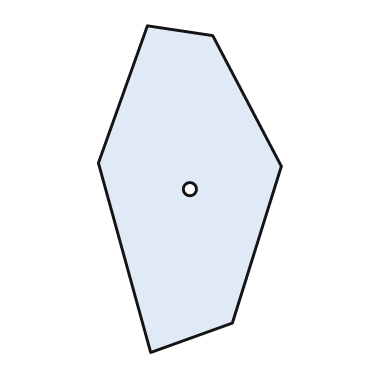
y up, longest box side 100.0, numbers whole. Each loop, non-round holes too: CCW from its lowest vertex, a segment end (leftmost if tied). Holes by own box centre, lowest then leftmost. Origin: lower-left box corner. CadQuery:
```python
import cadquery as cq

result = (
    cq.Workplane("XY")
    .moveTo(16.0, 0.0)
    .lineTo(41.0, 9.0)
    .lineTo(56.0, 57.0)
    .lineTo(35.0, 97.0)
    .lineTo(15.0, 100.0)
    .lineTo(0.0, 58.0)
    .close()
    .moveTo(28.0, 50.0)
    .circle(2.0)
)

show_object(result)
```